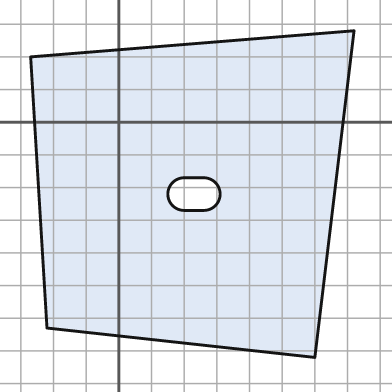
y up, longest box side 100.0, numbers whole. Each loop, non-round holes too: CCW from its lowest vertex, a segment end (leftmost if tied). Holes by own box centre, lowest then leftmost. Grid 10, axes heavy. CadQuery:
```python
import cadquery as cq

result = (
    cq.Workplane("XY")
    .moveTo(60.0, -72.0)
    .lineTo(72.0, 28.0)
    .lineTo(-27.0, 20.0)
    .lineTo(-22.0, -63.0)
    .close()
    .moveTo(20.0, -27.0)
    .lineTo(26.0, -27.0)
    .threePointArc((31.0, -22.0), (26.0, -17.0))
    .lineTo(20.0, -17.0)
    .threePointArc((15.0, -22.0), (20.0, -27.0))
    .close()
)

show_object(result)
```